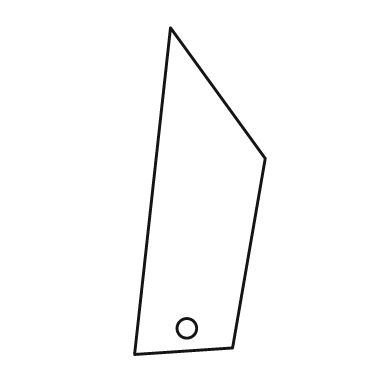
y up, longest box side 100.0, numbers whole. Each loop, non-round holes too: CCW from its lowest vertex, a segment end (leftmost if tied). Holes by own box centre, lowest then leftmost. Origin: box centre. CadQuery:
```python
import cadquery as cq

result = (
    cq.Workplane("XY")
    .moveTo(-20.0, -50.0)
    .lineTo(10.0, -48.0)
    .lineTo(20.0, 10.0)
    .lineTo(-9.0, 50.0)
    .close()
    .moveTo(-4.0, -42.0)
    .circle(3.0)
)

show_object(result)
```